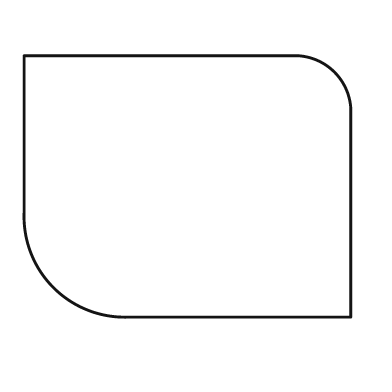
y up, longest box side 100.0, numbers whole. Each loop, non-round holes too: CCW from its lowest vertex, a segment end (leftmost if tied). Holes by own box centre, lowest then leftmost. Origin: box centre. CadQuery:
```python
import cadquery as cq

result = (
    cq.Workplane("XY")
    .moveTo(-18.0, -40.0)
    .lineTo(50.0, -40.0)
    .lineTo(50.0, 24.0)
    .threePointArc((45.0, 35.0), (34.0, 40.0))
    .lineTo(-50.0, 40.0)
    .lineTo(-50.0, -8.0)
    .threePointArc((-41.0, -31.0), (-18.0, -40.0))
    .close()
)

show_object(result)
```